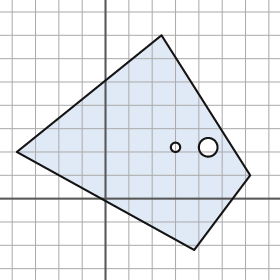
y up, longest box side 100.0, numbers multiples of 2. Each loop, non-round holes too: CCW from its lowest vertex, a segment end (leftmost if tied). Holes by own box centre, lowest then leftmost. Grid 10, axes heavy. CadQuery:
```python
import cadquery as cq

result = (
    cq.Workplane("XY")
    .moveTo(38.0, -22.0)
    .lineTo(62.0, 10.0)
    .lineTo(24.0, 70.0)
    .lineTo(-38.0, 20.0)
    .close()
    .moveTo(30.0, 22.0)
    .circle(2.0)
    .moveTo(44.0, 22.0)
    .circle(4.0)
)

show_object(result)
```